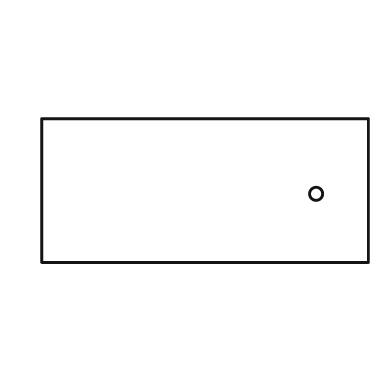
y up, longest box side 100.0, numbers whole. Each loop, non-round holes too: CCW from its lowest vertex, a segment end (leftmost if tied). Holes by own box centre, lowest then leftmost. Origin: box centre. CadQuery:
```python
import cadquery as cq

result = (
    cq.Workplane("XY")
    .moveTo(-50.0, -22.0)
    .lineTo(50.0, -22.0)
    .lineTo(50.0, 22.0)
    .lineTo(-50.0, 22.0)
    .close()
    .moveTo(34.0, -1.0)
    .circle(2.0)
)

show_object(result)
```